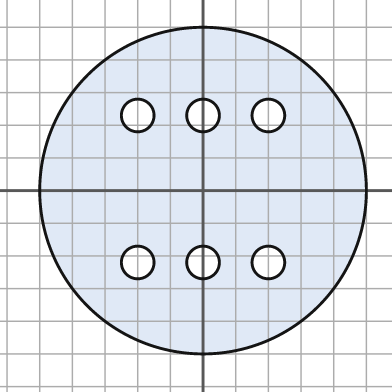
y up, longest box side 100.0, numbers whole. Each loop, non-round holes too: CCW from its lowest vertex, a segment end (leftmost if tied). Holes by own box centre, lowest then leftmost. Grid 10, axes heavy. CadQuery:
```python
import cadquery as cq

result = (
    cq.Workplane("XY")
    .moveTo(0.0, 0.0)
    .circle(50.0)
    .moveTo(-20.0, -22.0)
    .circle(5.0)
    .moveTo(0.0, -22.0)
    .circle(5.0)
    .moveTo(20.0, -22.0)
    .circle(5.0)
    .moveTo(-20.0, 23.0)
    .circle(5.0)
    .moveTo(0.0, 23.0)
    .circle(5.0)
    .moveTo(20.0, 23.0)
    .circle(5.0)
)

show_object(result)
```